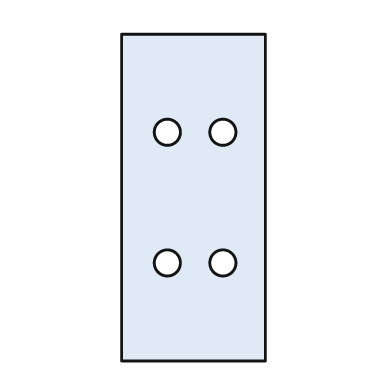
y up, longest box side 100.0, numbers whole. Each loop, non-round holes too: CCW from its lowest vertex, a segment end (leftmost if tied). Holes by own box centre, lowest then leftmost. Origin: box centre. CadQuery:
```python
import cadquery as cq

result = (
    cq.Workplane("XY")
    .moveTo(-22.0, -50.0)
    .lineTo(22.0, -50.0)
    .lineTo(22.0, 50.0)
    .lineTo(-22.0, 50.0)
    .close()
    .moveTo(-8.0, -20.0)
    .circle(4.0)
    .moveTo(9.0, -20.0)
    .circle(4.0)
    .moveTo(-8.0, 20.0)
    .circle(4.0)
    .moveTo(9.0, 20.0)
    .circle(4.0)
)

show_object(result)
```